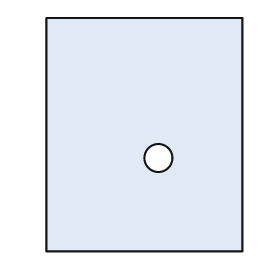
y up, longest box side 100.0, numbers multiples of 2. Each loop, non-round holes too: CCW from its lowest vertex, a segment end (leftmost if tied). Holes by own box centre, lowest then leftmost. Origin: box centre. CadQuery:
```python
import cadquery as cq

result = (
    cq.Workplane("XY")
    .moveTo(-42.0, -50.0)
    .lineTo(42.0, -50.0)
    .lineTo(42.0, 50.0)
    .lineTo(-42.0, 50.0)
    .close()
    .moveTo(6.0, -10.0)
    .circle(6.0)
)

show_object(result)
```